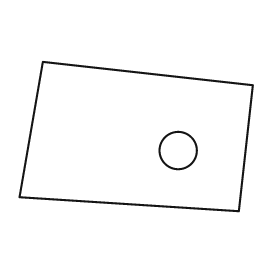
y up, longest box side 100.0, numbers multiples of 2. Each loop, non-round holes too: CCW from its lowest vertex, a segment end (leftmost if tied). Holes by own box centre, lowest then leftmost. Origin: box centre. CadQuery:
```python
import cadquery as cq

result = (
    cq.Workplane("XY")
    .moveTo(44.0, -32.0)
    .lineTo(50.0, 22.0)
    .lineTo(-40.0, 32.0)
    .lineTo(-50.0, -26.0)
    .close()
    .moveTo(18.0, -6.0)
    .circle(8.0)
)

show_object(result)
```